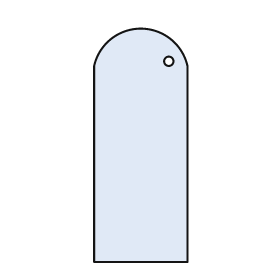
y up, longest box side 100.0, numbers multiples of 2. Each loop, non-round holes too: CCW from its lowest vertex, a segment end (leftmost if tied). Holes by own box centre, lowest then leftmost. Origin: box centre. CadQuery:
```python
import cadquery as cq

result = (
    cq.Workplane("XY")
    .moveTo(-20.0, -50.0)
    .lineTo(20.0, -50.0)
    .lineTo(20.0, 34.0)
    .threePointArc((0.0, 50.0), (-20.0, 34.0))
    .close()
    .moveTo(12.0, 36.0)
    .circle(2.0)
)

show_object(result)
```